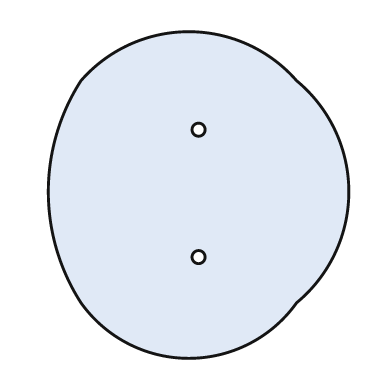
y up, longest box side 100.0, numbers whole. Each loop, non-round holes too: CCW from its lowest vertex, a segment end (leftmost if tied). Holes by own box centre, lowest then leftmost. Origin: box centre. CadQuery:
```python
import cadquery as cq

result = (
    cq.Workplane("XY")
    .moveTo(-36.0, -33.0)
    .threePointArc((-3.0, -50.0), (30.0, -33.0))
    .threePointArc((46.0, 1.0), (30.0, 35.0))
    .threePointArc((-3.0, 50.0), (-36.0, 35.0))
    .threePointArc((-46.0, 1.0), (-36.0, -33.0))
    .close()
    .moveTo(0.0, -19.0)
    .circle(2.0)
    .moveTo(0.0, 20.0)
    .circle(2.0)
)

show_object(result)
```